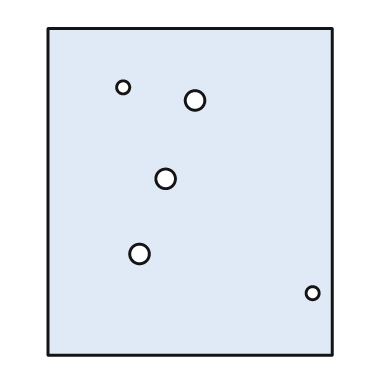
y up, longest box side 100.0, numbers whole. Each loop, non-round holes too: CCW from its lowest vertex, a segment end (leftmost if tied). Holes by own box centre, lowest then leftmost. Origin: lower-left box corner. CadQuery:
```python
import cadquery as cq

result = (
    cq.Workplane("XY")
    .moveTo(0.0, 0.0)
    .lineTo(87.0, 0.0)
    .lineTo(87.0, 100.0)
    .lineTo(0.0, 100.0)
    .close()
    .moveTo(81.0, 19.0)
    .circle(2.0)
    .moveTo(28.0, 31.0)
    .circle(3.0)
    .moveTo(36.0, 54.0)
    .circle(3.0)
    .moveTo(45.0, 78.0)
    .circle(3.0)
    .moveTo(23.0, 82.0)
    .circle(2.0)
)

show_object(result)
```